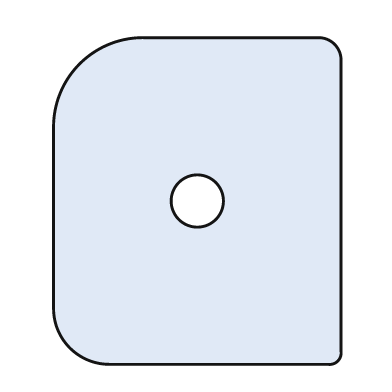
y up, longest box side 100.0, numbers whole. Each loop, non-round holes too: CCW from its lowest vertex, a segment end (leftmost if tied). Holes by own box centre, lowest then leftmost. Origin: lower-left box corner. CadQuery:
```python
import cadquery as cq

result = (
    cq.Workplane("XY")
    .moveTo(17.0, 0.0)
    .lineTo(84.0, 0.0)
    .threePointArc((87.0, 1.0), (88.0, 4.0))
    .lineTo(88.0, 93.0)
    .threePointArc((86.0, 98.0), (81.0, 100.0))
    .lineTo(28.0, 100.0)
    .threePointArc((8.0, 92.0), (0.0, 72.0))
    .lineTo(0.0, 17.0)
    .threePointArc((5.0, 5.0), (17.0, 0.0))
    .close()
    .moveTo(44.0, 50.0)
    .circle(8.0)
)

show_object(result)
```